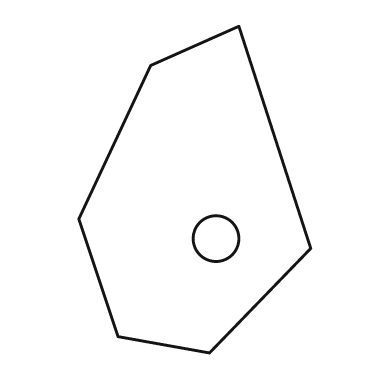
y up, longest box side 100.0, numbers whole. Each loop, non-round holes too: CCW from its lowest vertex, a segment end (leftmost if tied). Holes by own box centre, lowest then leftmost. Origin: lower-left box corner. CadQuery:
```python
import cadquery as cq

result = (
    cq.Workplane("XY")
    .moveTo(40.0, 0.0)
    .lineTo(71.0, 32.0)
    .lineTo(49.0, 100.0)
    .lineTo(22.0, 88.0)
    .lineTo(0.0, 41.0)
    .lineTo(12.0, 5.0)
    .close()
    .moveTo(42.0, 35.0)
    .circle(7.0)
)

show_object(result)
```